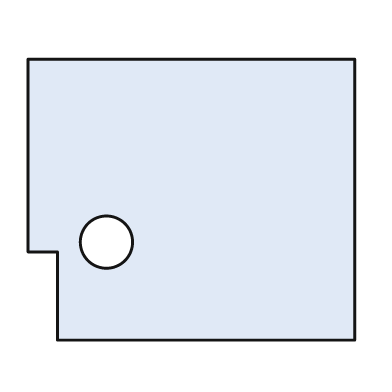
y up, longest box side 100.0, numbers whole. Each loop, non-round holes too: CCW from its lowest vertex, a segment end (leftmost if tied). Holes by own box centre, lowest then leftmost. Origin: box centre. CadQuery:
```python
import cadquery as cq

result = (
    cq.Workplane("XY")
    .moveTo(-41.0, -43.0)
    .lineTo(50.0, -43.0)
    .lineTo(50.0, 43.0)
    .lineTo(-50.0, 43.0)
    .lineTo(-50.0, -16.0)
    .lineTo(-41.0, -16.0)
    .close()
    .moveTo(-26.0, -13.0)
    .circle(8.0)
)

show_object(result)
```